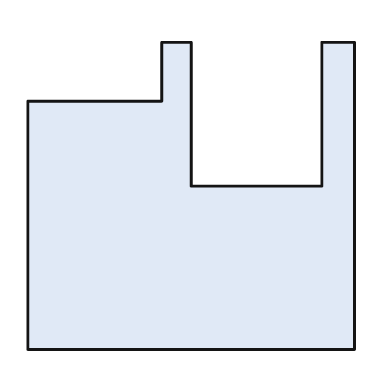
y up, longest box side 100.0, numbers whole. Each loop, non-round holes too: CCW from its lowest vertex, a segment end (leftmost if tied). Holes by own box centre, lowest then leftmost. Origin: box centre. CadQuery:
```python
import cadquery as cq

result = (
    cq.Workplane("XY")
    .moveTo(-50.0, -47.0)
    .lineTo(50.0, -47.0)
    .lineTo(50.0, 47.0)
    .lineTo(40.0, 47.0)
    .lineTo(40.0, 3.0)
    .lineTo(0.0, 3.0)
    .lineTo(0.0, 47.0)
    .lineTo(-9.0, 47.0)
    .lineTo(-9.0, 29.0)
    .lineTo(-50.0, 29.0)
    .close()
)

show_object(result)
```